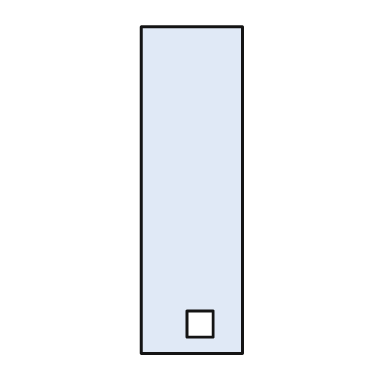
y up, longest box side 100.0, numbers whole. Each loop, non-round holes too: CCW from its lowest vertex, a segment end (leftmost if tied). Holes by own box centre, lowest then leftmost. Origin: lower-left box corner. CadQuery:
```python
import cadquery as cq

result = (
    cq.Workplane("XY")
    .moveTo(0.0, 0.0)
    .lineTo(31.0, 0.0)
    .lineTo(31.0, 100.0)
    .lineTo(0.0, 100.0)
    .close()
    .moveTo(14.0, 5.0)
    .lineTo(22.0, 5.0)
    .lineTo(22.0, 13.0)
    .lineTo(14.0, 13.0)
    .close()
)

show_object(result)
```